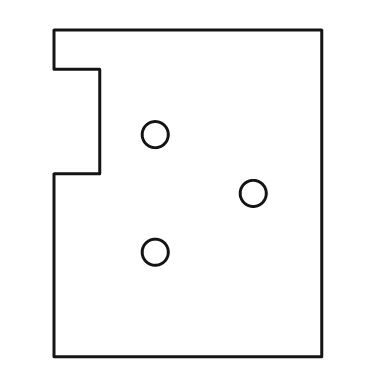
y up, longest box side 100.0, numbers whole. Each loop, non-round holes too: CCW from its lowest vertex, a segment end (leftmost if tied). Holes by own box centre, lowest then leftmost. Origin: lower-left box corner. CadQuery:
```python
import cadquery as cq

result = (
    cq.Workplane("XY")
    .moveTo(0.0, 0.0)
    .lineTo(82.0, 0.0)
    .lineTo(82.0, 100.0)
    .lineTo(0.0, 100.0)
    .lineTo(0.0, 88.0)
    .lineTo(14.0, 88.0)
    .lineTo(14.0, 56.0)
    .lineTo(0.0, 56.0)
    .close()
    .moveTo(31.0, 32.0)
    .circle(4.0)
    .moveTo(61.0, 50.0)
    .circle(4.0)
    .moveTo(31.0, 68.0)
    .circle(4.0)
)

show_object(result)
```